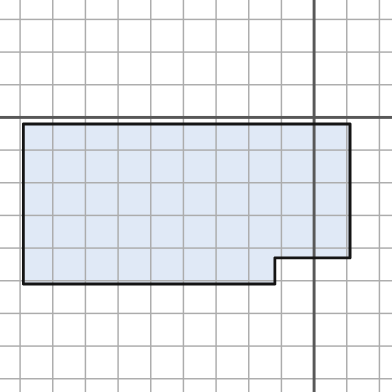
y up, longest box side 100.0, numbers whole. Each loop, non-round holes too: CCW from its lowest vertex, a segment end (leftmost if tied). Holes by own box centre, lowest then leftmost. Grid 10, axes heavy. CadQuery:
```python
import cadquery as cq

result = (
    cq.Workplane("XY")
    .moveTo(-89.0, -51.0)
    .lineTo(-12.0, -51.0)
    .lineTo(-12.0, -43.0)
    .lineTo(11.0, -43.0)
    .lineTo(11.0, -2.0)
    .lineTo(-89.0, -2.0)
    .close()
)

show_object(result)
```